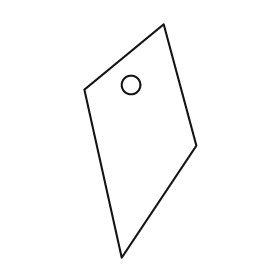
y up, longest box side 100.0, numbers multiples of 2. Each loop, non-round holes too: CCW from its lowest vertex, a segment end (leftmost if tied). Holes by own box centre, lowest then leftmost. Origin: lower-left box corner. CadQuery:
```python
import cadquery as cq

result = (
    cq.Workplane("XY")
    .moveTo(16.0, 0.0)
    .lineTo(48.0, 48.0)
    .lineTo(34.0, 100.0)
    .lineTo(0.0, 72.0)
    .close()
    .moveTo(20.0, 74.0)
    .circle(4.0)
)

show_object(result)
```